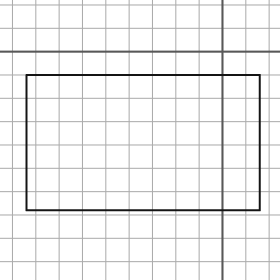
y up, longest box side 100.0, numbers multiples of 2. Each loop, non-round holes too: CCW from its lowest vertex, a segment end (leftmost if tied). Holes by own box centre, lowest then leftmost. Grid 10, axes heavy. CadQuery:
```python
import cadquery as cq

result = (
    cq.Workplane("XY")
    .moveTo(-84.0, -68.0)
    .lineTo(16.0, -68.0)
    .lineTo(16.0, -10.0)
    .lineTo(-84.0, -10.0)
    .close()
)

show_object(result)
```